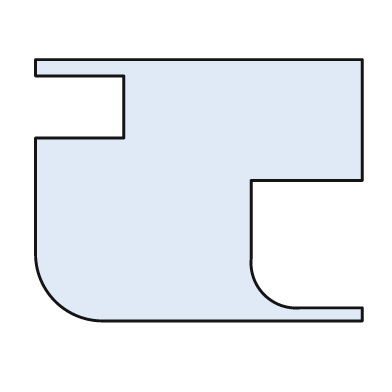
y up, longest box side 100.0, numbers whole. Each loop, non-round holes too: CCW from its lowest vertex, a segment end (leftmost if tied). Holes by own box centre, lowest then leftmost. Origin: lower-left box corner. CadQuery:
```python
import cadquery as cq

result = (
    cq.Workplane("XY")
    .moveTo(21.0, 0.0)
    .lineTo(100.0, 0.0)
    .lineTo(100.0, 4.0)
    .lineTo(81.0, 4.0)
    .threePointArc((70.0, 8.0), (66.0, 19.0))
    .lineTo(66.0, 43.0)
    .lineTo(100.0, 43.0)
    .lineTo(100.0, 80.0)
    .lineTo(0.0, 80.0)
    .lineTo(0.0, 75.0)
    .lineTo(27.0, 75.0)
    .lineTo(27.0, 56.0)
    .lineTo(0.0, 56.0)
    .lineTo(0.0, 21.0)
    .threePointArc((6.0, 6.0), (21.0, 0.0))
    .close()
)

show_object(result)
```